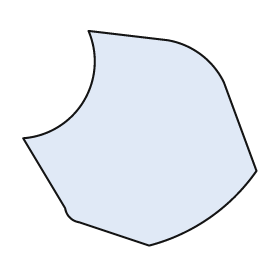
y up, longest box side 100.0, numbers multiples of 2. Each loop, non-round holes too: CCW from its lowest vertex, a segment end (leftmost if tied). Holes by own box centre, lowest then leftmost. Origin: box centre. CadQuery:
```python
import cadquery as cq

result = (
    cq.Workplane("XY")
    .moveTo(4.0, -46.0)
    .threePointArc((30.0, -34.0), (50.0, -14.0))
    .lineTo(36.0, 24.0)
    .threePointArc((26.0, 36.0), (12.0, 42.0))
    .lineTo(-22.0, 46.0)
    .threePointArc((-24.0, 16.0), (-50.0, 0.0))
    .lineTo(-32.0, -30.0)
    .threePointArc((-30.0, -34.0), (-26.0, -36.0))
    .close()
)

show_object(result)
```